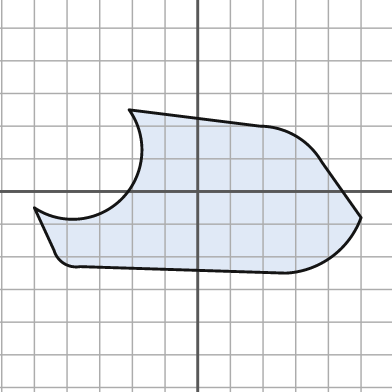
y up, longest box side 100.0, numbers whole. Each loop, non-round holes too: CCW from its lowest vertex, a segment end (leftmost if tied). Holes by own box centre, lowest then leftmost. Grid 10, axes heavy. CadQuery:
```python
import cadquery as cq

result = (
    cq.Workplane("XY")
    .moveTo(27.0, -25.0)
    .threePointArc((41.0, -20.0), (50.0, -8.0))
    .lineTo(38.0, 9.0)
    .threePointArc((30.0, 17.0), (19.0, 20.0))
    .lineTo(-21.0, 25.0)
    .threePointArc((-23.0, -2.0), (-50.0, -5.0))
    .lineTo(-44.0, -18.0)
    .threePointArc((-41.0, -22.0), (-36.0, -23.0))
    .close()
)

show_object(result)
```